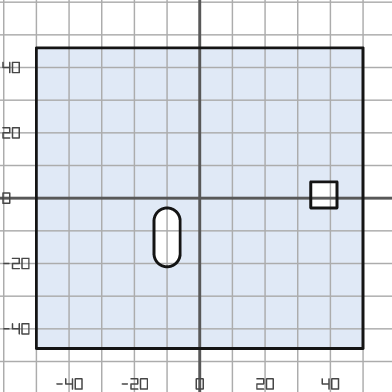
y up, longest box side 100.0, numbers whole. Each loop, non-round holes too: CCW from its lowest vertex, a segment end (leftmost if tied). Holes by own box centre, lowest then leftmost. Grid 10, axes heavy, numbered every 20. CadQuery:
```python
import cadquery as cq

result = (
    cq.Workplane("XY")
    .moveTo(-50.0, -46.0)
    .lineTo(50.0, -46.0)
    .lineTo(50.0, 46.0)
    .lineTo(-50.0, 46.0)
    .close()
    .moveTo(-14.0, -17.0)
    .threePointArc((-10.0, -21.0), (-6.0, -17.0))
    .lineTo(-6.0, -7.0)
    .threePointArc((-10.0, -3.0), (-14.0, -7.0))
    .close()
    .moveTo(34.0, -3.0)
    .lineTo(42.0, -3.0)
    .lineTo(42.0, 5.0)
    .lineTo(34.0, 5.0)
    .close()
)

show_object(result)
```